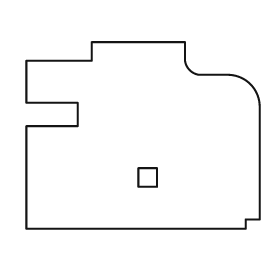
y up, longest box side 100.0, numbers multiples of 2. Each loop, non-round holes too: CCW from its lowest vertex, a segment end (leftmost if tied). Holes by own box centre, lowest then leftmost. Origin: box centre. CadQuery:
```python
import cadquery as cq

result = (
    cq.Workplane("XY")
    .moveTo(-50.0, -40.0)
    .lineTo(44.0, -40.0)
    .lineTo(44.0, -36.0)
    .lineTo(50.0, -36.0)
    .lineTo(50.0, 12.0)
    .threePointArc((46.0, 22.0), (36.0, 26.0))
    .lineTo(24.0, 26.0)
    .threePointArc((20.0, 28.0), (18.0, 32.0))
    .lineTo(18.0, 40.0)
    .lineTo(-22.0, 40.0)
    .lineTo(-22.0, 32.0)
    .lineTo(-50.0, 32.0)
    .lineTo(-50.0, 14.0)
    .lineTo(-28.0, 14.0)
    .lineTo(-28.0, 4.0)
    .lineTo(-50.0, 4.0)
    .close()
    .moveTo(-2.0, -22.0)
    .lineTo(6.0, -22.0)
    .lineTo(6.0, -14.0)
    .lineTo(-2.0, -14.0)
    .close()
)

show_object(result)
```